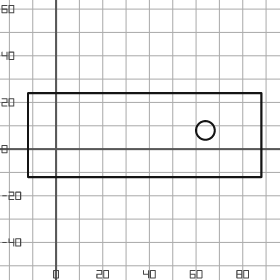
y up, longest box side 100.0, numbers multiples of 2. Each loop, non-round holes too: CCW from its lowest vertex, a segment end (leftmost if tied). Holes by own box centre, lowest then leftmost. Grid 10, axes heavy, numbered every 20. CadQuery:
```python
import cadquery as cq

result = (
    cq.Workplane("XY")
    .moveTo(-12.0, -12.0)
    .lineTo(88.0, -12.0)
    .lineTo(88.0, 24.0)
    .lineTo(-12.0, 24.0)
    .close()
    .moveTo(64.0, 8.0)
    .circle(4.0)
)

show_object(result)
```